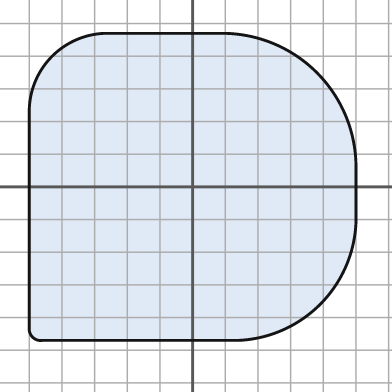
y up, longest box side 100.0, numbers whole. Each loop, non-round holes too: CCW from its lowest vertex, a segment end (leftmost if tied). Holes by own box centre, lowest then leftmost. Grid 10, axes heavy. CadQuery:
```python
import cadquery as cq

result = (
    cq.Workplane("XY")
    .moveTo(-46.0, -47.0)
    .lineTo(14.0, -47.0)
    .threePointArc((39.0, -36.0), (50.0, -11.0))
    .lineTo(50.0, 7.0)
    .threePointArc((38.0, 35.0), (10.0, 47.0))
    .lineTo(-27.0, 47.0)
    .threePointArc((-43.0, 40.0), (-50.0, 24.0))
    .lineTo(-50.0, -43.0)
    .threePointArc((-49.0, -46.0), (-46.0, -47.0))
    .close()
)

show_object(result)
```